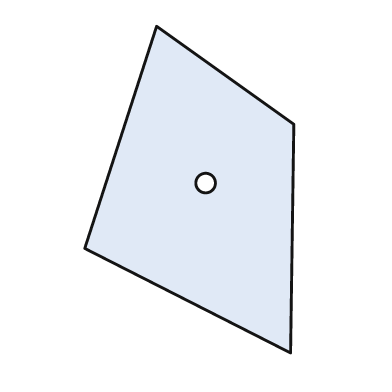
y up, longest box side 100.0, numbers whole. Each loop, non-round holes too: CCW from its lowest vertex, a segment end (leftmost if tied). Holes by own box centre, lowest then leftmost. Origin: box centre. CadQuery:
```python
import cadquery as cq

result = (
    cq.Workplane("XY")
    .moveTo(31.0, -50.0)
    .lineTo(32.0, 20.0)
    .lineTo(-10.0, 50.0)
    .lineTo(-32.0, -18.0)
    .close()
    .moveTo(5.0, 2.0)
    .circle(3.0)
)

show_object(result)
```